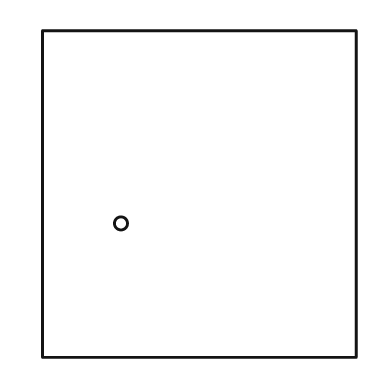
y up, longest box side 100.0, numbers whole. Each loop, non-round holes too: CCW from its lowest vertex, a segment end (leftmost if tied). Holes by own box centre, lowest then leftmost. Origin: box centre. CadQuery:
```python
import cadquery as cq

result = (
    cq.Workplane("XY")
    .moveTo(-48.0, -50.0)
    .lineTo(48.0, -50.0)
    .lineTo(48.0, 50.0)
    .lineTo(-48.0, 50.0)
    .close()
    .moveTo(-24.0, -9.0)
    .circle(2.0)
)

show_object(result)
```